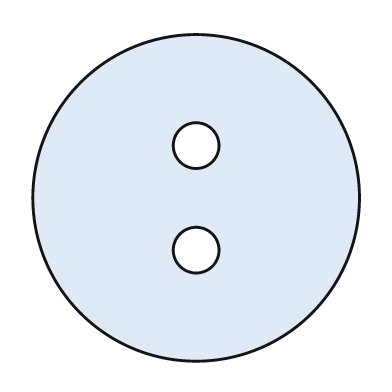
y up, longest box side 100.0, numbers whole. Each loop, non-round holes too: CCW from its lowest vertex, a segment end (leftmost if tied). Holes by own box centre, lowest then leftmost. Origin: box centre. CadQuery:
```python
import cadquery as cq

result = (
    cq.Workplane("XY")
    .moveTo(0.0, 0.0)
    .circle(50.0)
    .moveTo(0.0, -16.0)
    .circle(7.0)
    .moveTo(0.0, 16.0)
    .circle(7.0)
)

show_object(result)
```